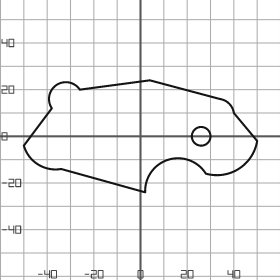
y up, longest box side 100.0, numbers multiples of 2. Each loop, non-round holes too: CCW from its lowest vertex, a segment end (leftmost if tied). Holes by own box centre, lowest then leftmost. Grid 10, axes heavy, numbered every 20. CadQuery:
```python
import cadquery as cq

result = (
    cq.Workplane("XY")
    .moveTo(2.0, -24.0)
    .threePointArc((12.0, -10.0), (28.0, -16.0))
    .threePointArc((42.0, -14.0), (50.0, -2.0))
    .lineTo(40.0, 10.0)
    .threePointArc((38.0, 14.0), (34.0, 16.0))
    .lineTo(4.0, 24.0)
    .lineTo(-26.0, 20.0)
    .threePointArc((-36.0, 22.0), (-38.0, 12.0))
    .lineTo(-50.0, -4.0)
    .threePointArc((-44.0, -12.0), (-34.0, -14.0))
    .close()
    .moveTo(26.0, 0.0)
    .circle(4.0)
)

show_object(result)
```